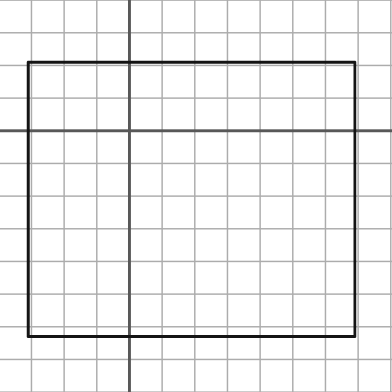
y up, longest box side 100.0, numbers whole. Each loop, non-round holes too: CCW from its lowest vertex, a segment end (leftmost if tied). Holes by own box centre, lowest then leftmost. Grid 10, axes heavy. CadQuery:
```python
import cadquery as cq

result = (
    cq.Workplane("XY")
    .moveTo(-31.0, -63.0)
    .lineTo(69.0, -63.0)
    .lineTo(69.0, 21.0)
    .lineTo(-31.0, 21.0)
    .close()
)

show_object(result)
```